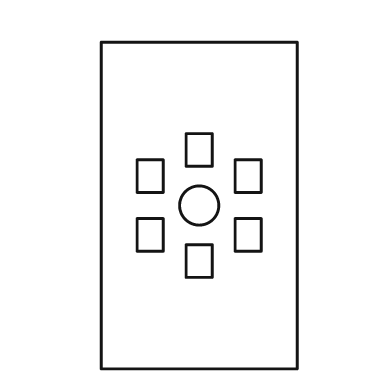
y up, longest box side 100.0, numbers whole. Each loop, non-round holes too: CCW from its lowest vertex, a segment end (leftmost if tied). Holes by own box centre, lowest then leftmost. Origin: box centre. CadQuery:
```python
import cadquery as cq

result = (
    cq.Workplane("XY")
    .moveTo(-30.0, -50.0)
    .lineTo(30.0, -50.0)
    .lineTo(30.0, 50.0)
    .lineTo(-30.0, 50.0)
    .close()
    .moveTo(-4.0, -22.0)
    .lineTo(4.0, -22.0)
    .lineTo(4.0, -12.0)
    .lineTo(-4.0, -12.0)
    .close()
    .moveTo(-19.0, -14.0)
    .lineTo(-11.0, -14.0)
    .lineTo(-11.0, -4.0)
    .lineTo(-19.0, -4.0)
    .close()
    .moveTo(11.0, -14.0)
    .lineTo(19.0, -14.0)
    .lineTo(19.0, -4.0)
    .lineTo(11.0, -4.0)
    .close()
    .moveTo(0.0, 0.0)
    .circle(6.0)
    .moveTo(-19.0, 4.0)
    .lineTo(-11.0, 4.0)
    .lineTo(-11.0, 14.0)
    .lineTo(-19.0, 14.0)
    .close()
    .moveTo(11.0, 4.0)
    .lineTo(19.0, 4.0)
    .lineTo(19.0, 14.0)
    .lineTo(11.0, 14.0)
    .close()
    .moveTo(-4.0, 12.0)
    .lineTo(4.0, 12.0)
    .lineTo(4.0, 22.0)
    .lineTo(-4.0, 22.0)
    .close()
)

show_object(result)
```